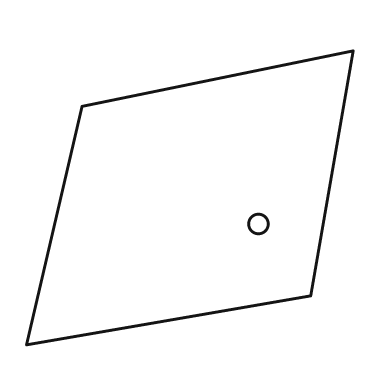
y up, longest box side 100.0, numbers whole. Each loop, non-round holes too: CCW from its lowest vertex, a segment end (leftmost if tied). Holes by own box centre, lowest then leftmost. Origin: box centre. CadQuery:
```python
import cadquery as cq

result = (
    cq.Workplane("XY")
    .moveTo(-50.0, -45.0)
    .lineTo(37.0, -30.0)
    .lineTo(50.0, 45.0)
    .lineTo(-33.0, 28.0)
    .close()
    .moveTo(21.0, -8.0)
    .circle(3.0)
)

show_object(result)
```